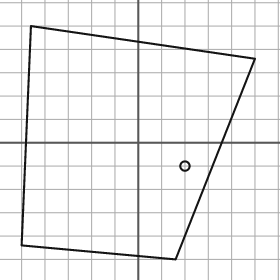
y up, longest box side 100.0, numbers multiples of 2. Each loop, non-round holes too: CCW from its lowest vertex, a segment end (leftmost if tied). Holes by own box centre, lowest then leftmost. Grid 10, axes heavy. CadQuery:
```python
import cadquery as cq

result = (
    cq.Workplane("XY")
    .moveTo(16.0, -50.0)
    .lineTo(50.0, 36.0)
    .lineTo(-46.0, 50.0)
    .lineTo(-50.0, -44.0)
    .close()
    .moveTo(20.0, -10.0)
    .circle(2.0)
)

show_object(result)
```